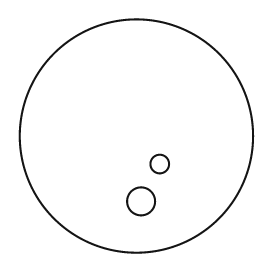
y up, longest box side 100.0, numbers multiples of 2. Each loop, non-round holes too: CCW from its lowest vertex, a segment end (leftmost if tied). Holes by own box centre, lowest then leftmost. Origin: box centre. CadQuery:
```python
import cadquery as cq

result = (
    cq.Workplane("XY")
    .moveTo(0.0, 0.0)
    .circle(50.0)
    .moveTo(2.0, -28.0)
    .circle(6.0)
    .moveTo(10.0, -12.0)
    .circle(4.0)
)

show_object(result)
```